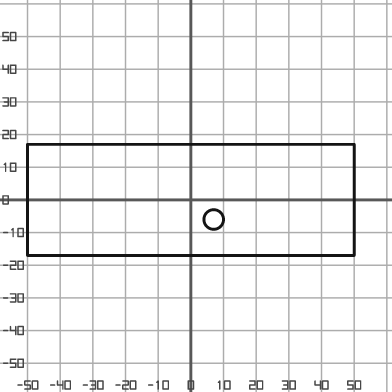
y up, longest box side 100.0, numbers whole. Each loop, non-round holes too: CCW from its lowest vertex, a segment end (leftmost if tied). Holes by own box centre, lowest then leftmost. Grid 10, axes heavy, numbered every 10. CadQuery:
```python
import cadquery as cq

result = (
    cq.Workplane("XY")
    .moveTo(-50.0, -17.0)
    .lineTo(50.0, -17.0)
    .lineTo(50.0, 17.0)
    .lineTo(-50.0, 17.0)
    .close()
    .moveTo(7.0, -6.0)
    .circle(3.0)
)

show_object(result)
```